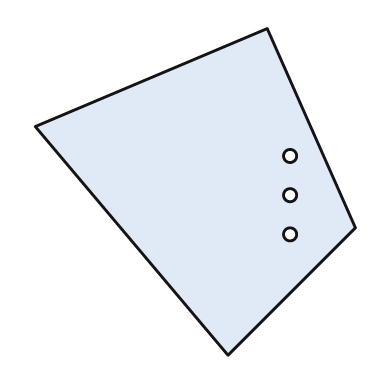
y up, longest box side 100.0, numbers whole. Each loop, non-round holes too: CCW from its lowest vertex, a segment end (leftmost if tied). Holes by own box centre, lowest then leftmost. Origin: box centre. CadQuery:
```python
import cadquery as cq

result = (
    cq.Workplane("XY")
    .moveTo(10.0, -50.0)
    .lineTo(49.0, -11.0)
    .lineTo(22.0, 50.0)
    .lineTo(-49.0, 20.0)
    .close()
    .moveTo(29.0, -13.0)
    .circle(2.0)
    .moveTo(29.0, -1.0)
    .circle(2.0)
    .moveTo(29.0, 11.0)
    .circle(2.0)
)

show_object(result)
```